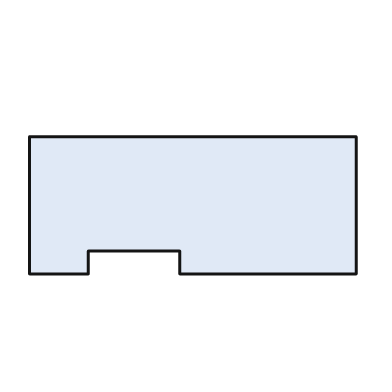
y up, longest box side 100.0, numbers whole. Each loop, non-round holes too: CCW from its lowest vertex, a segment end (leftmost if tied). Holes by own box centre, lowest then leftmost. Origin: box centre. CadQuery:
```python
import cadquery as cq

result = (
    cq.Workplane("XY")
    .moveTo(-50.0, -21.0)
    .lineTo(-32.0, -21.0)
    .lineTo(-32.0, -14.0)
    .lineTo(-4.0, -14.0)
    .lineTo(-4.0, -21.0)
    .lineTo(50.0, -21.0)
    .lineTo(50.0, 21.0)
    .lineTo(-50.0, 21.0)
    .close()
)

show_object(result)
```